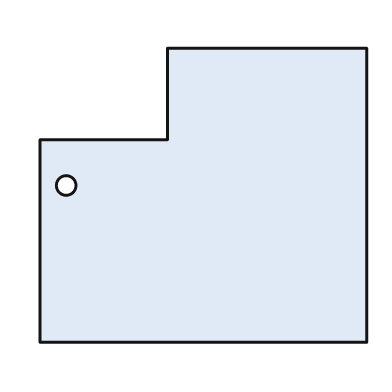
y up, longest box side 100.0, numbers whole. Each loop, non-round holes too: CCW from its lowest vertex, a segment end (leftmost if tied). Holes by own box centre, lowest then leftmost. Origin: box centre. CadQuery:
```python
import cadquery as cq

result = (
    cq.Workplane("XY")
    .moveTo(-50.0, -45.0)
    .lineTo(50.0, -45.0)
    .lineTo(50.0, 45.0)
    .lineTo(-11.0, 45.0)
    .lineTo(-11.0, 17.0)
    .lineTo(-50.0, 17.0)
    .close()
    .moveTo(-42.0, 3.0)
    .circle(3.0)
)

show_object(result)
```